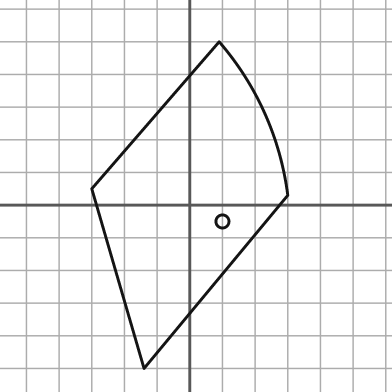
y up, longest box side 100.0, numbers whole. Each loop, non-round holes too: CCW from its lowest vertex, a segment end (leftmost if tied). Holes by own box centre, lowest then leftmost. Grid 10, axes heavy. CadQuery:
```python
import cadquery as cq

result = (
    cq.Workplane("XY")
    .moveTo(-14.0, -50.0)
    .lineTo(30.0, 3.0)
    .threePointArc((23.0, 28.0), (9.0, 50.0))
    .lineTo(-30.0, 5.0)
    .close()
    .moveTo(10.0, -5.0)
    .circle(2.0)
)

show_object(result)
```